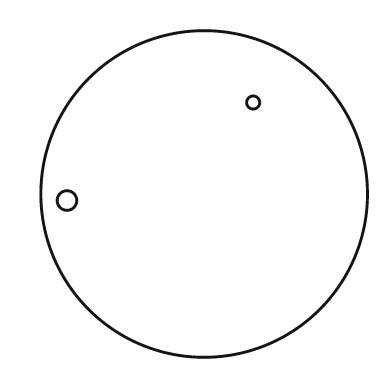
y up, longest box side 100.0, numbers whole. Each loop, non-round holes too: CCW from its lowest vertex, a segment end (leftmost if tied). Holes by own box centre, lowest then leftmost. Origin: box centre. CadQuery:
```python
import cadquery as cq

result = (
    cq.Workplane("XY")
    .moveTo(0.0, 0.0)
    .circle(50.0)
    .moveTo(-42.0, -2.0)
    .circle(3.0)
    .moveTo(15.0, 28.0)
    .circle(2.0)
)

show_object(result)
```